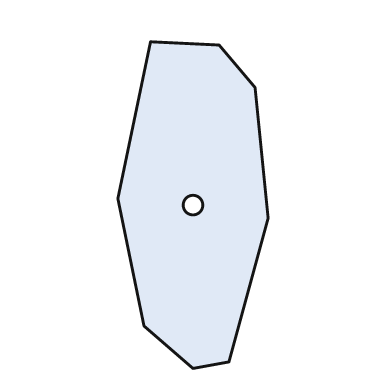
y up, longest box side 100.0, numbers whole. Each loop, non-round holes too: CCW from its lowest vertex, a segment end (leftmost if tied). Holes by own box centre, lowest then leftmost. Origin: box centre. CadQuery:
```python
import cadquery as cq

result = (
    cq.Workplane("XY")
    .moveTo(0.0, -50.0)
    .lineTo(11.0, -48.0)
    .lineTo(23.0, -4.0)
    .lineTo(19.0, 36.0)
    .lineTo(8.0, 49.0)
    .lineTo(-13.0, 50.0)
    .lineTo(-23.0, 2.0)
    .lineTo(-15.0, -37.0)
    .close()
    .moveTo(0.0, 0.0)
    .circle(3.0)
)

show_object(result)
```